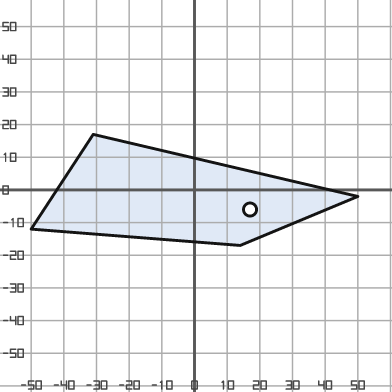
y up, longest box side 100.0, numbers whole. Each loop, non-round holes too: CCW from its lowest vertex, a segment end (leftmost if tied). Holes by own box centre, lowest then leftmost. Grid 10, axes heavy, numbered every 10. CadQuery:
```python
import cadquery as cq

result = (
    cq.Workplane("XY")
    .moveTo(14.0, -17.0)
    .lineTo(50.0, -2.0)
    .lineTo(-31.0, 17.0)
    .lineTo(-50.0, -12.0)
    .close()
    .moveTo(17.0, -6.0)
    .circle(2.0)
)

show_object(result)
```